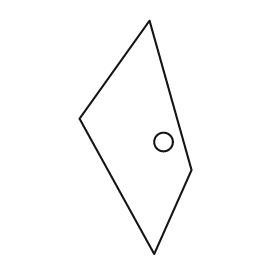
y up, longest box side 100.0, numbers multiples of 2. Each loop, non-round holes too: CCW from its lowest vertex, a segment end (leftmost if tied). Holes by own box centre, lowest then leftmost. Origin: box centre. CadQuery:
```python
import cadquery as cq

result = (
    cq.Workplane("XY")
    .moveTo(8.0, -50.0)
    .lineTo(24.0, -14.0)
    .lineTo(6.0, 50.0)
    .lineTo(-24.0, 8.0)
    .close()
    .moveTo(12.0, -2.0)
    .circle(4.0)
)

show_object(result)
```